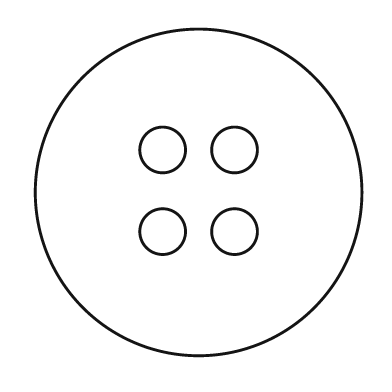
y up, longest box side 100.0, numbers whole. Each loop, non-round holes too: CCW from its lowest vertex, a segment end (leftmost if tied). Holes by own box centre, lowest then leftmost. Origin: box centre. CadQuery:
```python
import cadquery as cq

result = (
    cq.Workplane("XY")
    .moveTo(0.0, 0.0)
    .circle(50.0)
    .moveTo(-11.0, -12.0)
    .circle(7.0)
    .moveTo(11.0, -12.0)
    .circle(7.0)
    .moveTo(-11.0, 13.0)
    .circle(7.0)
    .moveTo(11.0, 13.0)
    .circle(7.0)
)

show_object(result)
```